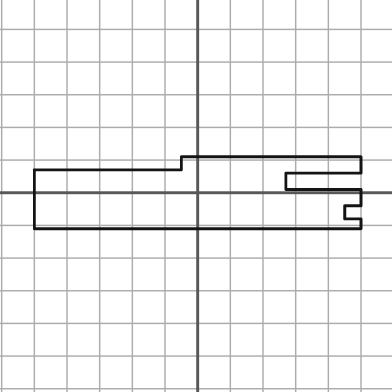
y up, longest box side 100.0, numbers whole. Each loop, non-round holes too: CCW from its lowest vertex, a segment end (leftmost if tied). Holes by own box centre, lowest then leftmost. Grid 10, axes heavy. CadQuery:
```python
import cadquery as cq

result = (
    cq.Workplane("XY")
    .moveTo(-50.0, -11.0)
    .lineTo(50.0, -11.0)
    .lineTo(50.0, -8.0)
    .lineTo(45.0, -8.0)
    .lineTo(45.0, -4.0)
    .lineTo(50.0, -4.0)
    .lineTo(50.0, 1.0)
    .lineTo(27.0, 1.0)
    .lineTo(27.0, 6.0)
    .lineTo(50.0, 6.0)
    .lineTo(50.0, 11.0)
    .lineTo(-5.0, 11.0)
    .lineTo(-5.0, 7.0)
    .lineTo(-50.0, 7.0)
    .close()
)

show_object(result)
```